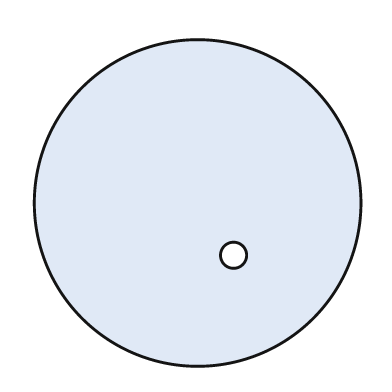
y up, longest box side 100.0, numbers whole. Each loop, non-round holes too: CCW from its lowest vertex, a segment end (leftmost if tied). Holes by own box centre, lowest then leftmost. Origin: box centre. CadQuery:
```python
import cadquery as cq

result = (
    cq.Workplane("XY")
    .moveTo(0.0, 0.0)
    .circle(50.0)
    .moveTo(11.0, -16.0)
    .circle(4.0)
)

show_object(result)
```